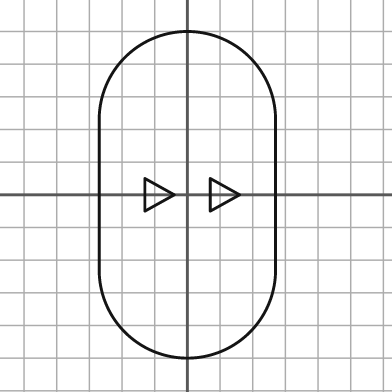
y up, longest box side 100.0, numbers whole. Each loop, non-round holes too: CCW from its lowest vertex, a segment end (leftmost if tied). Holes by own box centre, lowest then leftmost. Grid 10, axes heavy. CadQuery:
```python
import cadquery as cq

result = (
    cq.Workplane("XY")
    .moveTo(-27.0, -23.0)
    .threePointArc((0.0, -50.0), (27.0, -23.0))
    .lineTo(27.0, 23.0)
    .threePointArc((0.0, 50.0), (-27.0, 23.0))
    .close()
    .moveTo(-13.0, -5.0)
    .lineTo(-4.0, 0.0)
    .lineTo(-13.0, 5.0)
    .close()
    .moveTo(7.0, -5.0)
    .lineTo(16.0, 0.0)
    .lineTo(7.0, 5.0)
    .close()
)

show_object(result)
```